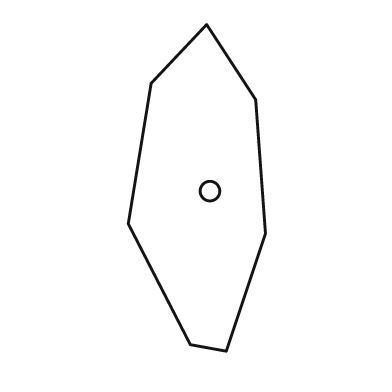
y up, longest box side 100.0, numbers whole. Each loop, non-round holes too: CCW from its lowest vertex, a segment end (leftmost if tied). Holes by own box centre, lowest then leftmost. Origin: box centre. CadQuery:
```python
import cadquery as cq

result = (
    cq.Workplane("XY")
    .moveTo(9.0, -50.0)
    .lineTo(21.0, -14.0)
    .lineTo(18.0, 27.0)
    .lineTo(3.0, 50.0)
    .lineTo(-14.0, 32.0)
    .lineTo(-21.0, -11.0)
    .lineTo(-2.0, -48.0)
    .close()
    .moveTo(4.0, -1.0)
    .circle(3.0)
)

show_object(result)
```